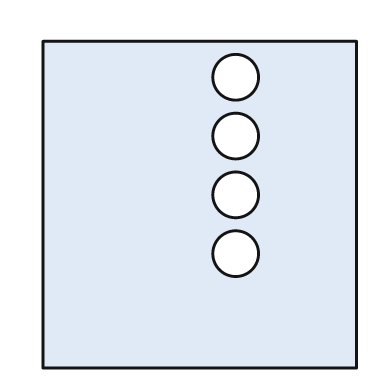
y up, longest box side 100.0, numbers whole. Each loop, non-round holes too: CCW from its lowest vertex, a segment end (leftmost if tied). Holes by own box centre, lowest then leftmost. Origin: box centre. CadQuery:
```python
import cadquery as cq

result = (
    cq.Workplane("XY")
    .moveTo(-48.0, -50.0)
    .lineTo(48.0, -50.0)
    .lineTo(48.0, 50.0)
    .lineTo(-48.0, 50.0)
    .close()
    .moveTo(11.0, -15.0)
    .circle(7.0)
    .moveTo(11.0, 3.0)
    .circle(7.0)
    .moveTo(11.0, 21.0)
    .circle(7.0)
    .moveTo(11.0, 39.0)
    .circle(7.0)
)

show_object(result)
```